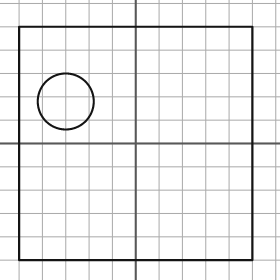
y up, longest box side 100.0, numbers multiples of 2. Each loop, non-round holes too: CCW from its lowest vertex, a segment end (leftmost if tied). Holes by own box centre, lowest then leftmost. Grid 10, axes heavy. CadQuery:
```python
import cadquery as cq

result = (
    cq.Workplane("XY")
    .moveTo(-50.0, -50.0)
    .lineTo(50.0, -50.0)
    .lineTo(50.0, 50.0)
    .lineTo(-50.0, 50.0)
    .close()
    .moveTo(-30.0, 18.0)
    .circle(12.0)
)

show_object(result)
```